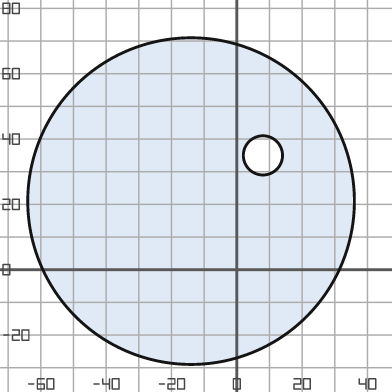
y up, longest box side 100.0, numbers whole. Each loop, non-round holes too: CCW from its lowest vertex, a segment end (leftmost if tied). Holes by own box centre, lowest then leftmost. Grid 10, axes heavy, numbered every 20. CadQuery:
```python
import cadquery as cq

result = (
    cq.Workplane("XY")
    .moveTo(-14.0, 21.0)
    .circle(50.0)
    .moveTo(8.0, 35.0)
    .circle(6.0)
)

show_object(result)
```